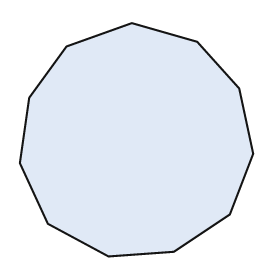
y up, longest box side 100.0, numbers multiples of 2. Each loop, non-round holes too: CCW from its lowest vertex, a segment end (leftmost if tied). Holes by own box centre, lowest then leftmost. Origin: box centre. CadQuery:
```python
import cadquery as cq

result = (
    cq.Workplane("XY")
    .moveTo(-12.0, -50.0)
    .lineTo(16.0, -48.0)
    .lineTo(40.0, -32.0)
    .lineTo(50.0, -6.0)
    .lineTo(44.0, 22.0)
    .lineTo(26.0, 42.0)
    .lineTo(-2.0, 50.0)
    .lineTo(-30.0, 40.0)
    .lineTo(-46.0, 18.0)
    .lineTo(-50.0, -10.0)
    .lineTo(-38.0, -36.0)
    .close()
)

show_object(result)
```